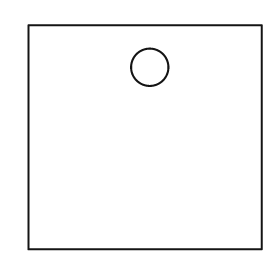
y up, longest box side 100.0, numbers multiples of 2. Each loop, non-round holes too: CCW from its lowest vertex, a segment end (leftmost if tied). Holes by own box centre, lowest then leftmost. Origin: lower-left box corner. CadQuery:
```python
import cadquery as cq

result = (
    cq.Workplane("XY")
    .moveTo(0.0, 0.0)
    .lineTo(100.0, 0.0)
    .lineTo(100.0, 96.0)
    .lineTo(0.0, 96.0)
    .close()
    .moveTo(52.0, 78.0)
    .circle(8.0)
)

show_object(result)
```